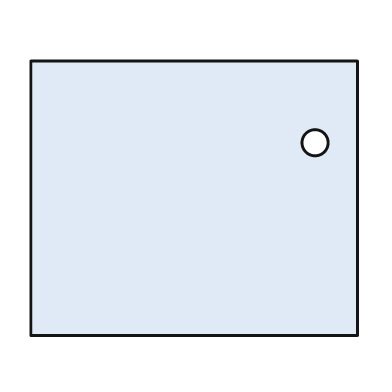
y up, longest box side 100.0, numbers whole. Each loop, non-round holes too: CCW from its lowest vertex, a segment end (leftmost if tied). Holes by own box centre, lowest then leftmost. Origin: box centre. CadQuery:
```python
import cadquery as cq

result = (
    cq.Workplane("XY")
    .moveTo(-50.0, -42.0)
    .lineTo(50.0, -42.0)
    .lineTo(50.0, 42.0)
    .lineTo(-50.0, 42.0)
    .close()
    .moveTo(37.0, 17.0)
    .circle(4.0)
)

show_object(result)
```